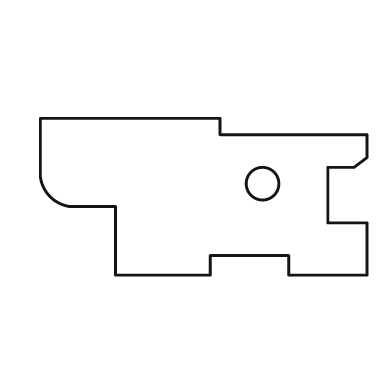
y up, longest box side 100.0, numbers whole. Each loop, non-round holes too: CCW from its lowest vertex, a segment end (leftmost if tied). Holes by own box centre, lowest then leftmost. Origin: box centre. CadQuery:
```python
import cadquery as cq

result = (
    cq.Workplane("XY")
    .moveTo(-27.0, -24.0)
    .lineTo(2.0, -24.0)
    .lineTo(2.0, -18.0)
    .lineTo(26.0, -18.0)
    .lineTo(26.0, -24.0)
    .lineTo(50.0, -24.0)
    .lineTo(50.0, -8.0)
    .lineTo(38.0, -8.0)
    .lineTo(38.0, 9.0)
    .lineTo(46.0, 9.0)
    .lineTo(50.0, 12.0)
    .lineTo(50.0, 19.0)
    .lineTo(5.0, 19.0)
    .lineTo(5.0, 24.0)
    .lineTo(-50.0, 24.0)
    .lineTo(-50.0, 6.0)
    .threePointArc((-47.0, 0.0), (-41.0, -3.0))
    .lineTo(-27.0, -3.0)
    .close()
    .moveTo(18.0, 4.0)
    .circle(5.0)
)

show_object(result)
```